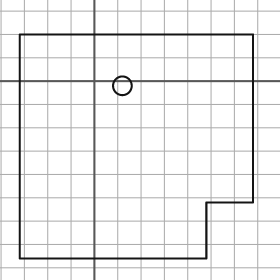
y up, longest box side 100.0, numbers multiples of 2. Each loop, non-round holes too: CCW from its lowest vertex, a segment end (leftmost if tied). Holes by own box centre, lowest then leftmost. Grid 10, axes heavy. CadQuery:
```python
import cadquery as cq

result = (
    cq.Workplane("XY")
    .moveTo(-32.0, -76.0)
    .lineTo(48.0, -76.0)
    .lineTo(48.0, -52.0)
    .lineTo(68.0, -52.0)
    .lineTo(68.0, 20.0)
    .lineTo(-32.0, 20.0)
    .close()
    .moveTo(12.0, -2.0)
    .circle(4.0)
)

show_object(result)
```